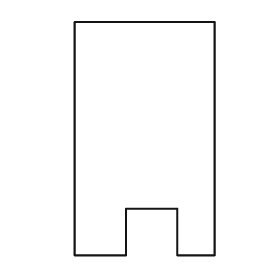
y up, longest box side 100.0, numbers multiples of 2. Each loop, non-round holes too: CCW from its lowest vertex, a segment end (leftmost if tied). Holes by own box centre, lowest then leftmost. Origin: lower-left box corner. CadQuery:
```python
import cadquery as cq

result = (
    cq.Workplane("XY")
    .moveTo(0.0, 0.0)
    .lineTo(22.0, 0.0)
    .lineTo(22.0, 20.0)
    .lineTo(44.0, 20.0)
    .lineTo(44.0, 0.0)
    .lineTo(60.0, 0.0)
    .lineTo(60.0, 100.0)
    .lineTo(0.0, 100.0)
    .close()
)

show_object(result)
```